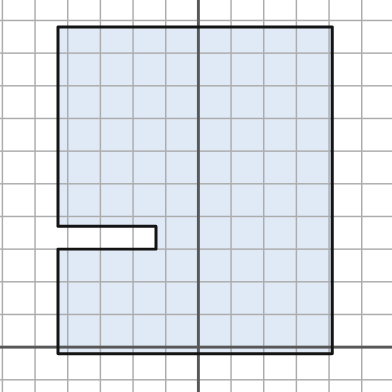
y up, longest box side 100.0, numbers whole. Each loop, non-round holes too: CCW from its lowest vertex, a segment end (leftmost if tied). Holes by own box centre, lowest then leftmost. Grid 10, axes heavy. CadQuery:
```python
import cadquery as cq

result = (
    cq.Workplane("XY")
    .moveTo(-43.0, -2.0)
    .lineTo(41.0, -2.0)
    .lineTo(41.0, 98.0)
    .lineTo(-43.0, 98.0)
    .lineTo(-43.0, 37.0)
    .lineTo(-13.0, 37.0)
    .lineTo(-13.0, 30.0)
    .lineTo(-43.0, 30.0)
    .close()
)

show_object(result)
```